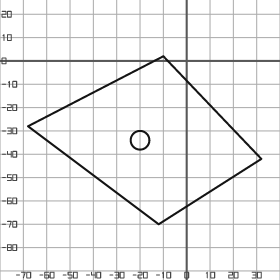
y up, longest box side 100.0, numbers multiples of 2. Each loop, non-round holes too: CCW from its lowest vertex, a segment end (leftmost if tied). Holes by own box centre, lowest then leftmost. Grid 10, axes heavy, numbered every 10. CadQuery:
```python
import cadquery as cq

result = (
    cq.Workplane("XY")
    .moveTo(-12.0, -70.0)
    .lineTo(32.0, -42.0)
    .lineTo(-10.0, 2.0)
    .lineTo(-68.0, -28.0)
    .close()
    .moveTo(-20.0, -34.0)
    .circle(4.0)
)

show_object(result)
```